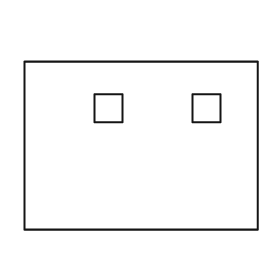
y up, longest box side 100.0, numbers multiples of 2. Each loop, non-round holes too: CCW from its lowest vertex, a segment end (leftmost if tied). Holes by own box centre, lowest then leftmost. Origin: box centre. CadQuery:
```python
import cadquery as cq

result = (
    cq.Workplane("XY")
    .moveTo(-50.0, -36.0)
    .lineTo(50.0, -36.0)
    .lineTo(50.0, 36.0)
    .lineTo(-50.0, 36.0)
    .close()
    .moveTo(-20.0, 10.0)
    .lineTo(-8.0, 10.0)
    .lineTo(-8.0, 22.0)
    .lineTo(-20.0, 22.0)
    .close()
    .moveTo(22.0, 10.0)
    .lineTo(34.0, 10.0)
    .lineTo(34.0, 22.0)
    .lineTo(22.0, 22.0)
    .close()
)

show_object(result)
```